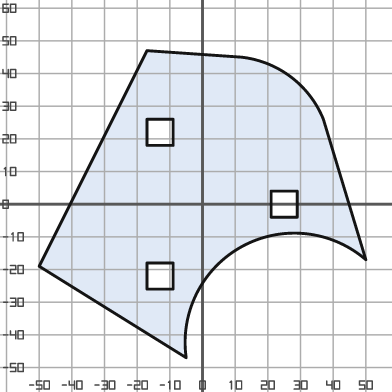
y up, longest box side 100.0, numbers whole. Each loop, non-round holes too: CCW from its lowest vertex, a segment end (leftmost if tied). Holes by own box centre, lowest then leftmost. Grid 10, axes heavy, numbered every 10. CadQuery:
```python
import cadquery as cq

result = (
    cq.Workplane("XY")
    .moveTo(-5.0, -47.0)
    .threePointArc((12.0, -13.0), (50.0, -17.0))
    .lineTo(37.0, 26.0)
    .threePointArc((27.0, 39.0), (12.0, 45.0))
    .lineTo(-17.0, 47.0)
    .lineTo(-50.0, -19.0)
    .close()
    .moveTo(-17.0, -26.0)
    .lineTo(-9.0, -26.0)
    .lineTo(-9.0, -18.0)
    .lineTo(-17.0, -18.0)
    .close()
    .moveTo(21.0, -4.0)
    .lineTo(29.0, -4.0)
    .lineTo(29.0, 4.0)
    .lineTo(21.0, 4.0)
    .close()
    .moveTo(-17.0, 18.0)
    .lineTo(-9.0, 18.0)
    .lineTo(-9.0, 26.0)
    .lineTo(-17.0, 26.0)
    .close()
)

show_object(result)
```